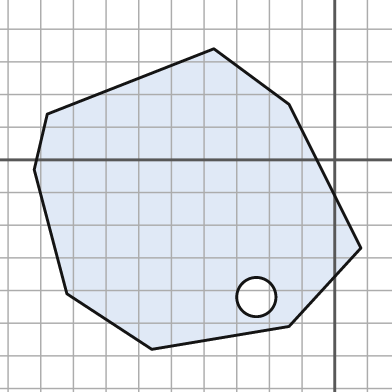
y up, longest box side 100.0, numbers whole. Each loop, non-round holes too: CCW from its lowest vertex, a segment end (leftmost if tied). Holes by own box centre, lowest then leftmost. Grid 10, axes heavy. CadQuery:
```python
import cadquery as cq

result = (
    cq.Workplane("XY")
    .moveTo(-56.0, -58.0)
    .lineTo(-14.0, -51.0)
    .lineTo(8.0, -27.0)
    .lineTo(-14.0, 17.0)
    .lineTo(-37.0, 34.0)
    .lineTo(-88.0, 14.0)
    .lineTo(-92.0, -3.0)
    .lineTo(-82.0, -41.0)
    .close()
    .moveTo(-24.0, -42.0)
    .circle(6.0)
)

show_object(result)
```